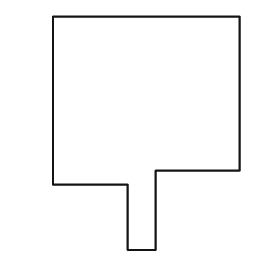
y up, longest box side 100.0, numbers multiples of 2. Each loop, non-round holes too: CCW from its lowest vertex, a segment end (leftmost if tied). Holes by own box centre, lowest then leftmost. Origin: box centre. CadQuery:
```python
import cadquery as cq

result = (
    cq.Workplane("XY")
    .moveTo(-8.0, -50.0)
    .lineTo(4.0, -50.0)
    .lineTo(4.0, -16.0)
    .lineTo(40.0, -16.0)
    .lineTo(40.0, 50.0)
    .lineTo(-40.0, 50.0)
    .lineTo(-40.0, -22.0)
    .lineTo(-8.0, -22.0)
    .close()
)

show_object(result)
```